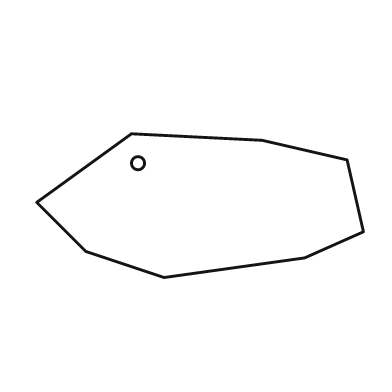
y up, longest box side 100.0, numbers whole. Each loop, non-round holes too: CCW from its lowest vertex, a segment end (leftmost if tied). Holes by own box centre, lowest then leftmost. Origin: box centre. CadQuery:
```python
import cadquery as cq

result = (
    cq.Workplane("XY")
    .moveTo(-11.0, -22.0)
    .lineTo(32.0, -16.0)
    .lineTo(50.0, -8.0)
    .lineTo(45.0, 14.0)
    .lineTo(19.0, 20.0)
    .lineTo(-21.0, 22.0)
    .lineTo(-50.0, 1.0)
    .lineTo(-35.0, -14.0)
    .close()
    .moveTo(-19.0, 13.0)
    .circle(2.0)
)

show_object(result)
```